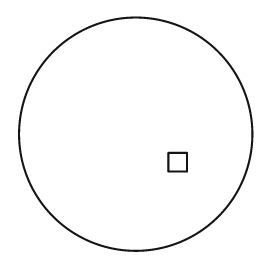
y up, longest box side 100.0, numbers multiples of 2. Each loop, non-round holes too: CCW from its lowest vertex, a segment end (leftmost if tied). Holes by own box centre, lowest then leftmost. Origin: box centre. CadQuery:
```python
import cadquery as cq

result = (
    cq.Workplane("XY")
    .moveTo(0.0, 0.0)
    .circle(50.0)
    .moveTo(14.0, -16.0)
    .lineTo(22.0, -16.0)
    .lineTo(22.0, -8.0)
    .lineTo(14.0, -8.0)
    .close()
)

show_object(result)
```